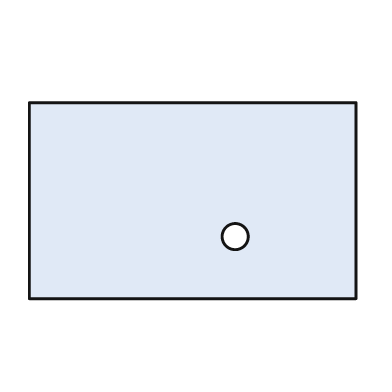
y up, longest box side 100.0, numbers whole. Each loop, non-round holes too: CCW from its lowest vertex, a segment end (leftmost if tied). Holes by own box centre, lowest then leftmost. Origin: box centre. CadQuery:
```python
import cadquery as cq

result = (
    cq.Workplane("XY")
    .moveTo(-50.0, -30.0)
    .lineTo(50.0, -30.0)
    .lineTo(50.0, 30.0)
    .lineTo(-50.0, 30.0)
    .close()
    .moveTo(13.0, -11.0)
    .circle(4.0)
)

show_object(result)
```